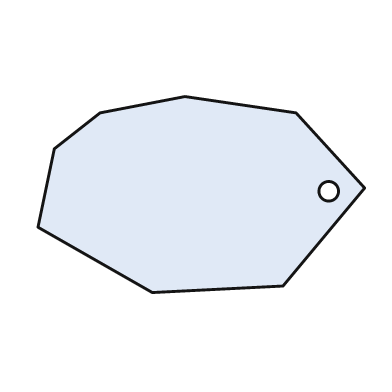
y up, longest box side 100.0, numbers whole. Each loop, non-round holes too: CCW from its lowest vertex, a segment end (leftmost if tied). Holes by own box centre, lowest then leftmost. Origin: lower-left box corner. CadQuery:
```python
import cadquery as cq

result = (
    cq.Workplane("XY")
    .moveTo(35.0, 0.0)
    .lineTo(75.0, 2.0)
    .lineTo(100.0, 32.0)
    .lineTo(79.0, 55.0)
    .lineTo(45.0, 60.0)
    .lineTo(19.0, 55.0)
    .lineTo(5.0, 44.0)
    .lineTo(0.0, 20.0)
    .close()
    .moveTo(89.0, 31.0)
    .circle(3.0)
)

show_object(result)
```